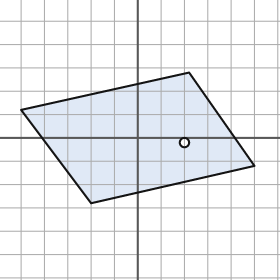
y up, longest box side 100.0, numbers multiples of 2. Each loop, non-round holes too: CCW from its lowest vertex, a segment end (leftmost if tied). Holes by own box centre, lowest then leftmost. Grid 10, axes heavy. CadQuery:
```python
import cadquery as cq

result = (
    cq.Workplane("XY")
    .moveTo(-20.0, -28.0)
    .lineTo(50.0, -12.0)
    .lineTo(22.0, 28.0)
    .lineTo(-50.0, 12.0)
    .close()
    .moveTo(20.0, -2.0)
    .circle(2.0)
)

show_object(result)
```